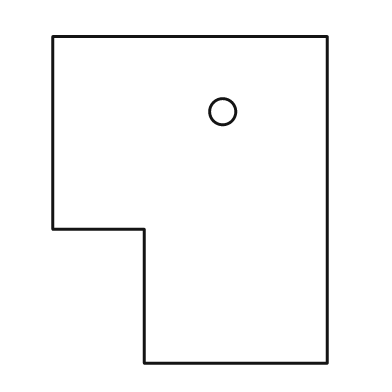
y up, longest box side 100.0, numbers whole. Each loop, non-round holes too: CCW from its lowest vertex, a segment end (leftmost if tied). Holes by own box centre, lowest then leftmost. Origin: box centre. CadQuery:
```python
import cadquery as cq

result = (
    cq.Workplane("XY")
    .moveTo(-14.0, -50.0)
    .lineTo(42.0, -50.0)
    .lineTo(42.0, 50.0)
    .lineTo(-42.0, 50.0)
    .lineTo(-42.0, -9.0)
    .lineTo(-14.0, -9.0)
    .close()
    .moveTo(10.0, 27.0)
    .circle(4.0)
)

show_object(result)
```